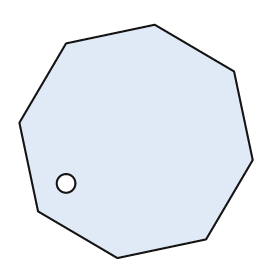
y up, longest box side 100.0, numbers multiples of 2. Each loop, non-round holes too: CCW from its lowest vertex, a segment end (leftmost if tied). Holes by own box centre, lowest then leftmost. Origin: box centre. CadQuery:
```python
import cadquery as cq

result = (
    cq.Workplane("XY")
    .moveTo(-8.0, -50.0)
    .lineTo(30.0, -42.0)
    .lineTo(50.0, -8.0)
    .lineTo(42.0, 30.0)
    .lineTo(8.0, 50.0)
    .lineTo(-30.0, 42.0)
    .lineTo(-50.0, 8.0)
    .lineTo(-42.0, -30.0)
    .close()
    .moveTo(-30.0, -18.0)
    .circle(4.0)
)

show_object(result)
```